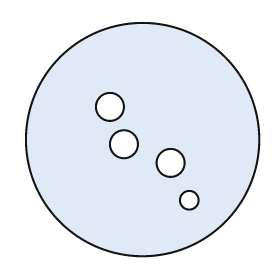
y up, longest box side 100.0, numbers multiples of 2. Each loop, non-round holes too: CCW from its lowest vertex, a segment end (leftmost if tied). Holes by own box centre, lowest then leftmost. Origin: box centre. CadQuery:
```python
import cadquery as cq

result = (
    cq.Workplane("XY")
    .moveTo(0.0, 0.0)
    .circle(50.0)
    .moveTo(20.0, -26.0)
    .circle(4.0)
    .moveTo(12.0, -10.0)
    .circle(6.0)
    .moveTo(-8.0, -2.0)
    .circle(6.0)
    .moveTo(-14.0, 14.0)
    .circle(6.0)
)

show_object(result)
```